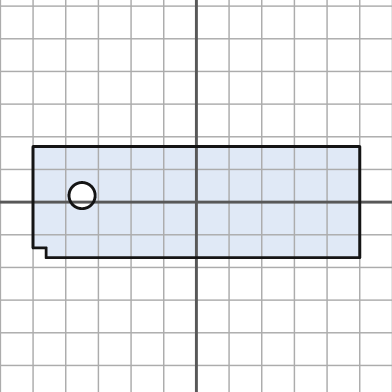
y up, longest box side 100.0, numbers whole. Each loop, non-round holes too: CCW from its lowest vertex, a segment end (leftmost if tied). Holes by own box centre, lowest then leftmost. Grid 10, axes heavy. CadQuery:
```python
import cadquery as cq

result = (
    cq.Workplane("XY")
    .moveTo(-46.0, -17.0)
    .lineTo(50.0, -17.0)
    .lineTo(50.0, 17.0)
    .lineTo(-50.0, 17.0)
    .lineTo(-50.0, -14.0)
    .lineTo(-46.0, -14.0)
    .close()
    .moveTo(-35.0, 2.0)
    .circle(4.0)
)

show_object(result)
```